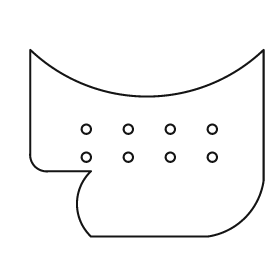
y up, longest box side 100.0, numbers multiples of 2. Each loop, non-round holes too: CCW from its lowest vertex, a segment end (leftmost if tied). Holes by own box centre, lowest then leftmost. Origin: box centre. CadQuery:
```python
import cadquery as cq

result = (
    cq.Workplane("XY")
    .moveTo(-24.0, -40.0)
    .lineTo(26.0, -40.0)
    .threePointArc((42.0, -32.0), (50.0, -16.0))
    .lineTo(50.0, 40.0)
    .threePointArc((0.0, 20.0), (-50.0, 40.0))
    .lineTo(-50.0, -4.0)
    .threePointArc((-48.0, -10.0), (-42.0, -12.0))
    .lineTo(-24.0, -12.0)
    .threePointArc((-30.0, -26.0), (-24.0, -40.0))
    .close()
    .moveTo(-26.0, -6.0)
    .circle(2.0)
    .moveTo(-8.0, -6.0)
    .circle(2.0)
    .moveTo(10.0, -6.0)
    .circle(2.0)
    .moveTo(28.0, -6.0)
    .circle(2.0)
    .moveTo(-26.0, 6.0)
    .circle(2.0)
    .moveTo(-8.0, 6.0)
    .circle(2.0)
    .moveTo(10.0, 6.0)
    .circle(2.0)
    .moveTo(28.0, 6.0)
    .circle(2.0)
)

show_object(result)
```